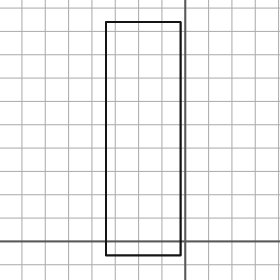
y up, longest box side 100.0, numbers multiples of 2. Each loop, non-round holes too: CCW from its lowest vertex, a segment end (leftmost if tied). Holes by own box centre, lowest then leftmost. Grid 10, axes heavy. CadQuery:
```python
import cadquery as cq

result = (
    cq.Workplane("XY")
    .moveTo(-34.0, -6.0)
    .lineTo(-2.0, -6.0)
    .lineTo(-2.0, 94.0)
    .lineTo(-34.0, 94.0)
    .close()
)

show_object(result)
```